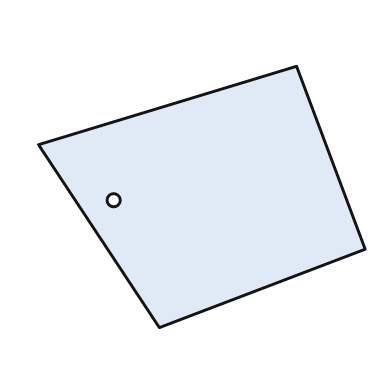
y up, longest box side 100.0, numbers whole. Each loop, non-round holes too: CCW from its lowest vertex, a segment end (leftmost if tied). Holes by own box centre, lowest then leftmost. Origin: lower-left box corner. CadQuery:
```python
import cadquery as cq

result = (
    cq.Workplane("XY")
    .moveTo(37.0, 0.0)
    .lineTo(100.0, 24.0)
    .lineTo(79.0, 80.0)
    .lineTo(0.0, 56.0)
    .close()
    .moveTo(23.0, 39.0)
    .circle(2.0)
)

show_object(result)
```